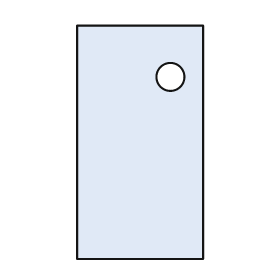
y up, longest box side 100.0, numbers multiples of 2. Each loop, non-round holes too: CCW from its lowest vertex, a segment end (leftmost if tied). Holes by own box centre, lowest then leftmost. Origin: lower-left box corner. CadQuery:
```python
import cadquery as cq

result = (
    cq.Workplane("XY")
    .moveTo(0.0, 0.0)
    .lineTo(54.0, 0.0)
    .lineTo(54.0, 100.0)
    .lineTo(0.0, 100.0)
    .close()
    .moveTo(40.0, 78.0)
    .circle(6.0)
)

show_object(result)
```